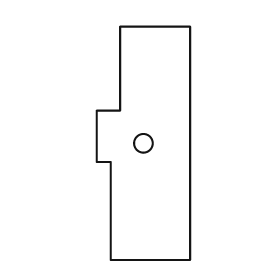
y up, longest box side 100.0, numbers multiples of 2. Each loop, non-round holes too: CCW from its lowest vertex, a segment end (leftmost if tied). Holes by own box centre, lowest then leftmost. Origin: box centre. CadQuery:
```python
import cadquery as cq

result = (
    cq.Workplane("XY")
    .moveTo(-14.0, -50.0)
    .lineTo(20.0, -50.0)
    .lineTo(20.0, 50.0)
    .lineTo(-10.0, 50.0)
    .lineTo(-10.0, 14.0)
    .lineTo(-20.0, 14.0)
    .lineTo(-20.0, -8.0)
    .lineTo(-14.0, -8.0)
    .close()
    .moveTo(0.0, 0.0)
    .circle(4.0)
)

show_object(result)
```